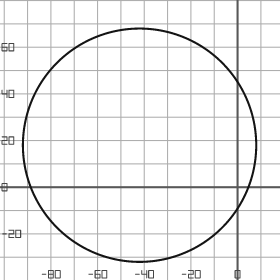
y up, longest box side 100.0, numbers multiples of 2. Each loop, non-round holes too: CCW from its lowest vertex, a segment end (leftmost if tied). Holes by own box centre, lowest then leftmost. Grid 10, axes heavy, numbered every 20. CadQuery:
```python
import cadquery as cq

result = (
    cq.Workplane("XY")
    .moveTo(-42.0, 18.0)
    .circle(50.0)
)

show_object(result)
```